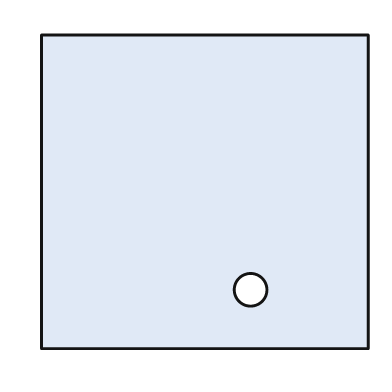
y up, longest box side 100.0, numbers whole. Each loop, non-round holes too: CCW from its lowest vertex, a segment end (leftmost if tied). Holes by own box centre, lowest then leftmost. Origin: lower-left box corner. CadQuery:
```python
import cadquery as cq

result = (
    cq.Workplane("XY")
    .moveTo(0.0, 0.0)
    .lineTo(100.0, 0.0)
    .lineTo(100.0, 96.0)
    .lineTo(0.0, 96.0)
    .close()
    .moveTo(64.0, 18.0)
    .circle(5.0)
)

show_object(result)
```